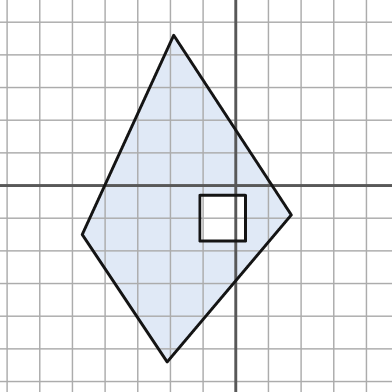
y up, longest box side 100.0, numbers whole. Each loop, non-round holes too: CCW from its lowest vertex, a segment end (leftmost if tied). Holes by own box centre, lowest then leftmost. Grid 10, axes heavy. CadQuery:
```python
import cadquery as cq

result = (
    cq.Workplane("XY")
    .moveTo(-21.0, -54.0)
    .lineTo(17.0, -9.0)
    .lineTo(-19.0, 46.0)
    .lineTo(-47.0, -15.0)
    .close()
    .moveTo(-11.0, -17.0)
    .lineTo(3.0, -17.0)
    .lineTo(3.0, -3.0)
    .lineTo(-11.0, -3.0)
    .close()
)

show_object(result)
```